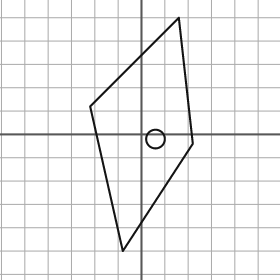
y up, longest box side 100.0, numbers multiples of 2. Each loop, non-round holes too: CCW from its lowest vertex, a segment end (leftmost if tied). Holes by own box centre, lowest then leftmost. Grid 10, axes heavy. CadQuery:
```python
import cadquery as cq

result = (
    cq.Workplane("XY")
    .moveTo(-8.0, -50.0)
    .lineTo(22.0, -4.0)
    .lineTo(16.0, 50.0)
    .lineTo(-22.0, 12.0)
    .close()
    .moveTo(6.0, -2.0)
    .circle(4.0)
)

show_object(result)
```